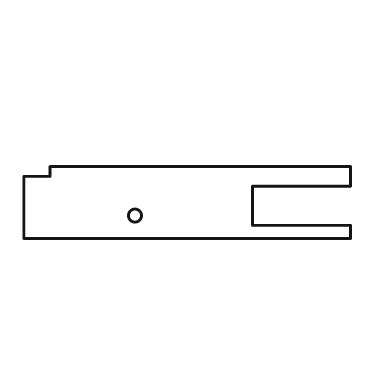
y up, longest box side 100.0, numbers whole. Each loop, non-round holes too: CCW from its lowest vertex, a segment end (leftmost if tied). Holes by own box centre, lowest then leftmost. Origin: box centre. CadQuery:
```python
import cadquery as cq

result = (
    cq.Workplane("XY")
    .moveTo(-50.0, -11.0)
    .lineTo(50.0, -11.0)
    .lineTo(50.0, -7.0)
    .lineTo(20.0, -7.0)
    .lineTo(20.0, 5.0)
    .lineTo(50.0, 5.0)
    .lineTo(50.0, 11.0)
    .lineTo(-42.0, 11.0)
    .lineTo(-42.0, 8.0)
    .lineTo(-50.0, 8.0)
    .close()
    .moveTo(-16.0, -4.0)
    .circle(2.0)
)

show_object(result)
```